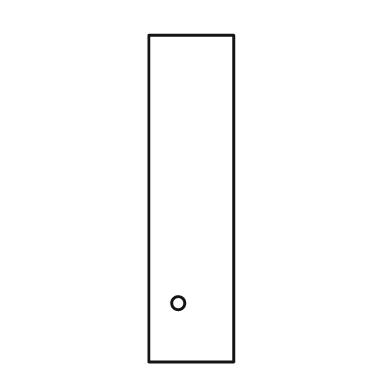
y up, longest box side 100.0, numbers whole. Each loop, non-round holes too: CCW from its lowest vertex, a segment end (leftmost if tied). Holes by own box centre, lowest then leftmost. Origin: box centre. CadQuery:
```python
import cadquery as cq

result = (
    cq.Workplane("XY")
    .moveTo(-13.0, -50.0)
    .lineTo(13.0, -50.0)
    .lineTo(13.0, 50.0)
    .lineTo(-13.0, 50.0)
    .close()
    .moveTo(-4.0, -32.0)
    .circle(2.0)
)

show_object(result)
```